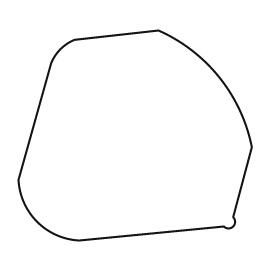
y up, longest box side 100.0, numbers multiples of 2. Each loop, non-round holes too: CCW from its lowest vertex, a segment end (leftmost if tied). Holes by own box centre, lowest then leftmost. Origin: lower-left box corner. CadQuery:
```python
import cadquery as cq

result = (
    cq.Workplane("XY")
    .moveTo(26.0, 0.0)
    .lineTo(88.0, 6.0)
    .threePointArc((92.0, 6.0), (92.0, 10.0))
    .lineTo(100.0, 40.0)
    .threePointArc((86.0, 70.0), (60.0, 90.0))
    .lineTo(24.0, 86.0)
    .threePointArc((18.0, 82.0), (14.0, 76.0))
    .lineTo(0.0, 26.0)
    .threePointArc((8.0, 8.0), (26.0, 0.0))
    .close()
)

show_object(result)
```